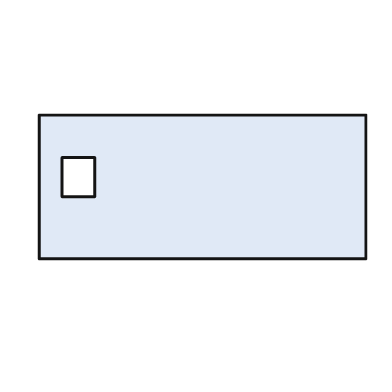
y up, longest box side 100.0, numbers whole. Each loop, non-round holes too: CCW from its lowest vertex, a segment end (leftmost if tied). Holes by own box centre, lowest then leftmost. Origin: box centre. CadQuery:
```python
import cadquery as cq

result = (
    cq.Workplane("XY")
    .moveTo(-50.0, -22.0)
    .lineTo(50.0, -22.0)
    .lineTo(50.0, 22.0)
    .lineTo(-50.0, 22.0)
    .close()
    .moveTo(-43.0, -3.0)
    .lineTo(-33.0, -3.0)
    .lineTo(-33.0, 9.0)
    .lineTo(-43.0, 9.0)
    .close()
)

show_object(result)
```